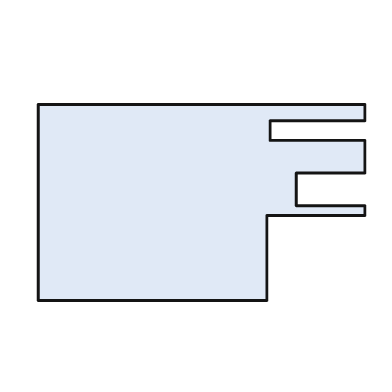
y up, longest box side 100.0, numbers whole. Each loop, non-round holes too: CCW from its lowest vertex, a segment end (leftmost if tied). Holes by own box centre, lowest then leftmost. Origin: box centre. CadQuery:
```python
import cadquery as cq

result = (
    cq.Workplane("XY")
    .moveTo(-50.0, -30.0)
    .lineTo(20.0, -30.0)
    .lineTo(20.0, -4.0)
    .lineTo(50.0, -4.0)
    .lineTo(50.0, -1.0)
    .lineTo(29.0, -1.0)
    .lineTo(29.0, 9.0)
    .lineTo(50.0, 9.0)
    .lineTo(50.0, 19.0)
    .lineTo(21.0, 19.0)
    .lineTo(21.0, 25.0)
    .lineTo(50.0, 25.0)
    .lineTo(50.0, 30.0)
    .lineTo(-50.0, 30.0)
    .close()
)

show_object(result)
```